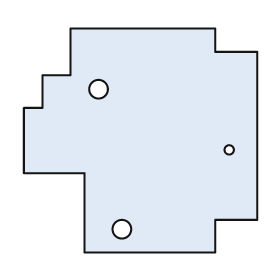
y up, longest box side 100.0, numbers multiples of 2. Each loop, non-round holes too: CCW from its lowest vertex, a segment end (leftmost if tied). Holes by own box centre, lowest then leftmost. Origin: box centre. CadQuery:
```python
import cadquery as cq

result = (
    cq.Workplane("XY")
    .moveTo(-24.0, -48.0)
    .lineTo(32.0, -48.0)
    .lineTo(32.0, -34.0)
    .lineTo(50.0, -34.0)
    .lineTo(50.0, 38.0)
    .lineTo(32.0, 38.0)
    .lineTo(32.0, 48.0)
    .lineTo(-30.0, 48.0)
    .lineTo(-30.0, 28.0)
    .lineTo(-42.0, 28.0)
    .lineTo(-42.0, 14.0)
    .lineTo(-50.0, 14.0)
    .lineTo(-50.0, -14.0)
    .lineTo(-24.0, -14.0)
    .close()
    .moveTo(-8.0, -38.0)
    .circle(4.0)
    .moveTo(38.0, -4.0)
    .circle(2.0)
    .moveTo(-18.0, 22.0)
    .circle(4.0)
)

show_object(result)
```